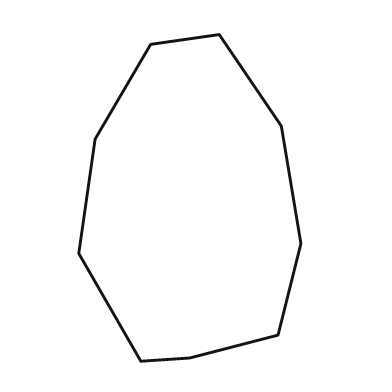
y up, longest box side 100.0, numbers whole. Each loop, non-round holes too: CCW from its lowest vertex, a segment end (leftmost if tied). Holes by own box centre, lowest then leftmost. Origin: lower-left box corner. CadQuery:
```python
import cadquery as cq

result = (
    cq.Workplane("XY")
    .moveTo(19.0, 0.0)
    .lineTo(34.0, 1.0)
    .lineTo(61.0, 8.0)
    .lineTo(68.0, 36.0)
    .lineTo(62.0, 72.0)
    .lineTo(43.0, 100.0)
    .lineTo(22.0, 97.0)
    .lineTo(5.0, 68.0)
    .lineTo(0.0, 33.0)
    .close()
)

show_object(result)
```